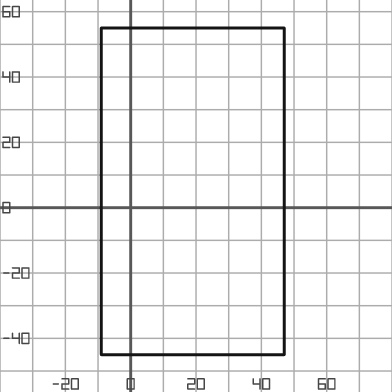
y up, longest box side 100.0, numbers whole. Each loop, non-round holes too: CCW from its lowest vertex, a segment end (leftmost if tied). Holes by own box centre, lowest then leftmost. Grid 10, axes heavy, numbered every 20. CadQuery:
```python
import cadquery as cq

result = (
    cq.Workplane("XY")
    .moveTo(-9.0, -45.0)
    .lineTo(47.0, -45.0)
    .lineTo(47.0, 55.0)
    .lineTo(-9.0, 55.0)
    .close()
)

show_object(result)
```